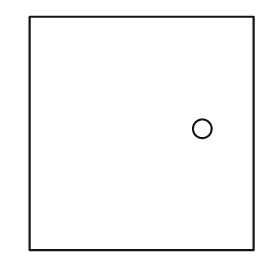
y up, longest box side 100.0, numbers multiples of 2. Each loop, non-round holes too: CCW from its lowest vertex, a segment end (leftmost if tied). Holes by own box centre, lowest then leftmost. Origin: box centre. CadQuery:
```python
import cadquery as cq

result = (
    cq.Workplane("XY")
    .moveTo(-48.0, -50.0)
    .lineTo(48.0, -50.0)
    .lineTo(48.0, 50.0)
    .lineTo(-48.0, 50.0)
    .close()
    .moveTo(26.0, 2.0)
    .circle(4.0)
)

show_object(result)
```